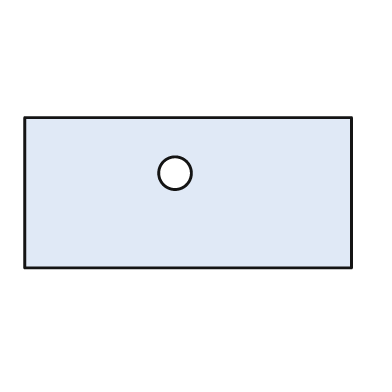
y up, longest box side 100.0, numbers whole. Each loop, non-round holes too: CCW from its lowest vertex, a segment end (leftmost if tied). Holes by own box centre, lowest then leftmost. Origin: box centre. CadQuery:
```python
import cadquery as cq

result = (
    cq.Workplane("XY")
    .moveTo(-50.0, -23.0)
    .lineTo(50.0, -23.0)
    .lineTo(50.0, 23.0)
    .lineTo(-50.0, 23.0)
    .close()
    .moveTo(-4.0, 6.0)
    .circle(5.0)
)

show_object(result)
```